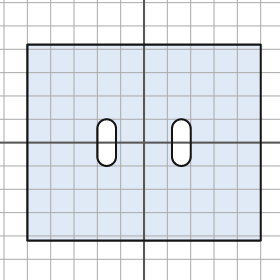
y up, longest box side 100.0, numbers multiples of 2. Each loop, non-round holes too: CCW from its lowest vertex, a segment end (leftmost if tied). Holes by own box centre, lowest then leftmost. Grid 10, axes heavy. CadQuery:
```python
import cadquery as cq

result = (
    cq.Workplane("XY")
    .moveTo(-50.0, -42.0)
    .lineTo(50.0, -42.0)
    .lineTo(50.0, 42.0)
    .lineTo(-50.0, 42.0)
    .close()
    .moveTo(-20.0, -6.0)
    .threePointArc((-16.0, -10.0), (-12.0, -6.0))
    .lineTo(-12.0, 6.0)
    .threePointArc((-16.0, 10.0), (-20.0, 6.0))
    .close()
    .moveTo(12.0, -6.0)
    .threePointArc((16.0, -10.0), (20.0, -6.0))
    .lineTo(20.0, 6.0)
    .threePointArc((16.0, 10.0), (12.0, 6.0))
    .close()
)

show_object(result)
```